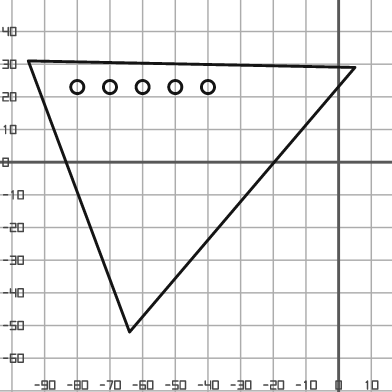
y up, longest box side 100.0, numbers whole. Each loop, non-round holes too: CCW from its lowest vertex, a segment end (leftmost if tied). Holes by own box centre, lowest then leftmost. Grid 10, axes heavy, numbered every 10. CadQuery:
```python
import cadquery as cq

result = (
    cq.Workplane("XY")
    .moveTo(-64.0, -52.0)
    .lineTo(5.0, 29.0)
    .lineTo(-95.0, 31.0)
    .close()
    .moveTo(-80.0, 23.0)
    .circle(2.0)
    .moveTo(-70.0, 23.0)
    .circle(2.0)
    .moveTo(-60.0, 23.0)
    .circle(2.0)
    .moveTo(-50.0, 23.0)
    .circle(2.0)
    .moveTo(-40.0, 23.0)
    .circle(2.0)
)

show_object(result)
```